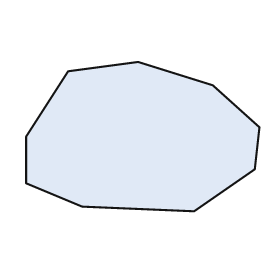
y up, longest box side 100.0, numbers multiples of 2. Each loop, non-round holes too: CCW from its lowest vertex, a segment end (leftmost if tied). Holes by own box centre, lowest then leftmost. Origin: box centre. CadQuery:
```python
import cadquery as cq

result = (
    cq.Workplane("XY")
    .moveTo(22.0, -32.0)
    .lineTo(48.0, -14.0)
    .lineTo(50.0, 4.0)
    .lineTo(30.0, 22.0)
    .lineTo(-2.0, 32.0)
    .lineTo(-32.0, 28.0)
    .lineTo(-50.0, 0.0)
    .lineTo(-50.0, -20.0)
    .lineTo(-26.0, -30.0)
    .close()
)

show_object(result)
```